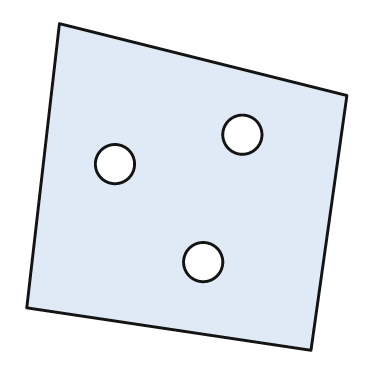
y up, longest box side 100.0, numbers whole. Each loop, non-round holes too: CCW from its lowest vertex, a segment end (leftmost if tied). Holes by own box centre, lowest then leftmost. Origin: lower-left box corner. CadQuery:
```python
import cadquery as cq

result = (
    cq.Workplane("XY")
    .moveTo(87.0, 0.0)
    .lineTo(98.0, 78.0)
    .lineTo(10.0, 100.0)
    .lineTo(0.0, 13.0)
    .close()
    .moveTo(54.0, 27.0)
    .circle(6.0)
    .moveTo(27.0, 57.0)
    .circle(6.0)
    .moveTo(66.0, 66.0)
    .circle(6.0)
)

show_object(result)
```